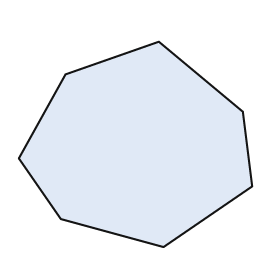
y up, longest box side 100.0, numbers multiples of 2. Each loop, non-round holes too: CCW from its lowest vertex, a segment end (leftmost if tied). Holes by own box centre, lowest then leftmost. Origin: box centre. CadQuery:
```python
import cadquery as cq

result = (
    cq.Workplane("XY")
    .moveTo(12.0, -44.0)
    .lineTo(50.0, -18.0)
    .lineTo(46.0, 14.0)
    .lineTo(10.0, 44.0)
    .lineTo(-30.0, 30.0)
    .lineTo(-50.0, -6.0)
    .lineTo(-32.0, -32.0)
    .close()
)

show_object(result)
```